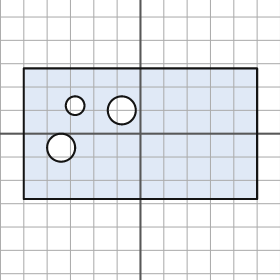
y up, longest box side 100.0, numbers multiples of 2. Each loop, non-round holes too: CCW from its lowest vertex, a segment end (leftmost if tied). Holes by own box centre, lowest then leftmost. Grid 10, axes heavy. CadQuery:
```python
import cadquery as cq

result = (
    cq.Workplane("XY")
    .moveTo(-50.0, -28.0)
    .lineTo(50.0, -28.0)
    .lineTo(50.0, 28.0)
    .lineTo(-50.0, 28.0)
    .close()
    .moveTo(-34.0, -6.0)
    .circle(6.0)
    .moveTo(-8.0, 10.0)
    .circle(6.0)
    .moveTo(-28.0, 12.0)
    .circle(4.0)
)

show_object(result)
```